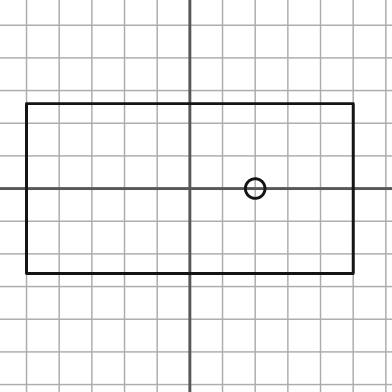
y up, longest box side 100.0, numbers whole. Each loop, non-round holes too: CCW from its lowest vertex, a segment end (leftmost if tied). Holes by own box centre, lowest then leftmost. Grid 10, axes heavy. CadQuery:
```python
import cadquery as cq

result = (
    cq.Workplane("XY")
    .moveTo(-50.0, -26.0)
    .lineTo(50.0, -26.0)
    .lineTo(50.0, 26.0)
    .lineTo(-50.0, 26.0)
    .close()
    .moveTo(20.0, 0.0)
    .circle(3.0)
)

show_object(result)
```